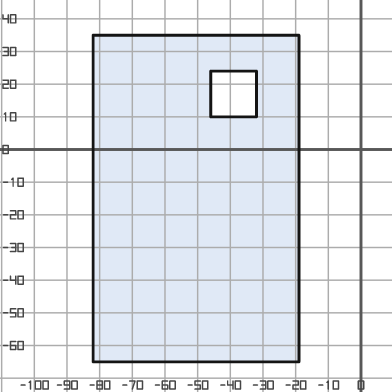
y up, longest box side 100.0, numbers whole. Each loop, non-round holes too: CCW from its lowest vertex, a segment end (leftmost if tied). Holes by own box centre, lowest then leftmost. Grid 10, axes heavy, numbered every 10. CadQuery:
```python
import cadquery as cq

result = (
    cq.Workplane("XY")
    .moveTo(-82.0, -65.0)
    .lineTo(-19.0, -65.0)
    .lineTo(-19.0, 35.0)
    .lineTo(-82.0, 35.0)
    .close()
    .moveTo(-46.0, 10.0)
    .lineTo(-32.0, 10.0)
    .lineTo(-32.0, 24.0)
    .lineTo(-46.0, 24.0)
    .close()
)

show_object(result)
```